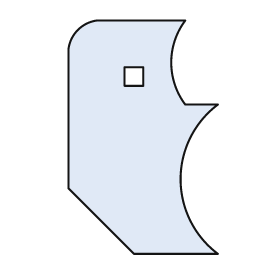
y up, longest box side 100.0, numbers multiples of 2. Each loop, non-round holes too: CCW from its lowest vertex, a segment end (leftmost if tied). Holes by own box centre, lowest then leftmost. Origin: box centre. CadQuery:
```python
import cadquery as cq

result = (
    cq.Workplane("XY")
    .moveTo(-4.0, -50.0)
    .lineTo(32.0, -50.0)
    .threePointArc((16.0, -18.0), (32.0, 14.0))
    .lineTo(18.0, 14.0)
    .threePointArc((12.0, 32.0), (18.0, 50.0))
    .lineTo(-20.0, 50.0)
    .threePointArc((-28.0, 46.0), (-32.0, 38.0))
    .lineTo(-32.0, -22.0)
    .close()
    .moveTo(-8.0, 22.0)
    .lineTo(0.0, 22.0)
    .lineTo(0.0, 30.0)
    .lineTo(-8.0, 30.0)
    .close()
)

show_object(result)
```